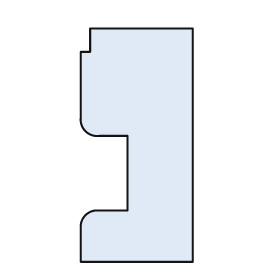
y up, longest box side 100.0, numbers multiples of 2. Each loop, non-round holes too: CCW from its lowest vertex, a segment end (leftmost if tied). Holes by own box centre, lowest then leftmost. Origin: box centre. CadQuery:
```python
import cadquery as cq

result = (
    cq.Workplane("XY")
    .moveTo(-24.0, -50.0)
    .lineTo(24.0, -50.0)
    .lineTo(24.0, 50.0)
    .lineTo(-20.0, 50.0)
    .lineTo(-20.0, 40.0)
    .lineTo(-24.0, 40.0)
    .lineTo(-24.0, 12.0)
    .threePointArc((-22.0, 6.0), (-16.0, 4.0))
    .lineTo(-4.0, 4.0)
    .lineTo(-4.0, -28.0)
    .lineTo(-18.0, -28.0)
    .threePointArc((-22.0, -30.0), (-24.0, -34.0))
    .close()
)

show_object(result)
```